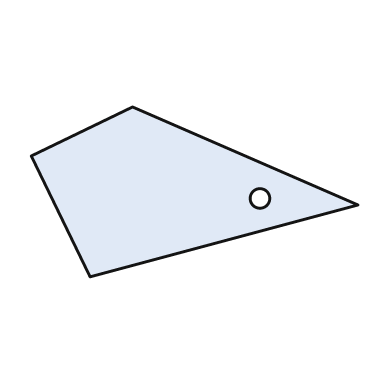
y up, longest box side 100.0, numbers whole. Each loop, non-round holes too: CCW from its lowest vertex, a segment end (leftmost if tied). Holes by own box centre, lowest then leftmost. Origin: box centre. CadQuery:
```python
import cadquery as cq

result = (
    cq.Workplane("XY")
    .moveTo(-32.0, -26.0)
    .lineTo(50.0, -4.0)
    .lineTo(-19.0, 26.0)
    .lineTo(-50.0, 11.0)
    .close()
    .moveTo(20.0, -2.0)
    .circle(3.0)
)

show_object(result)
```